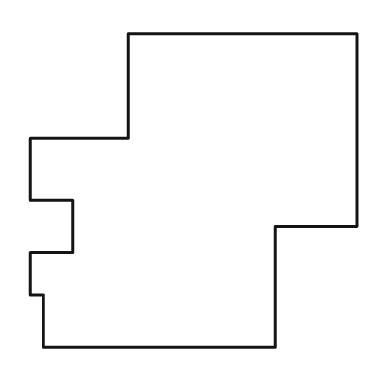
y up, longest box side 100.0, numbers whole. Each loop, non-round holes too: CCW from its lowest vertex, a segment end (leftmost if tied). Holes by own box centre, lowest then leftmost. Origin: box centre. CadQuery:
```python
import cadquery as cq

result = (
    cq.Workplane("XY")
    .moveTo(-46.0, -48.0)
    .lineTo(25.0, -48.0)
    .lineTo(25.0, -11.0)
    .lineTo(50.0, -11.0)
    .lineTo(50.0, 48.0)
    .lineTo(-20.0, 48.0)
    .lineTo(-20.0, 16.0)
    .lineTo(-50.0, 16.0)
    .lineTo(-50.0, -3.0)
    .lineTo(-37.0, -3.0)
    .lineTo(-37.0, -19.0)
    .lineTo(-50.0, -19.0)
    .lineTo(-50.0, -32.0)
    .lineTo(-46.0, -32.0)
    .close()
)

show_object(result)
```